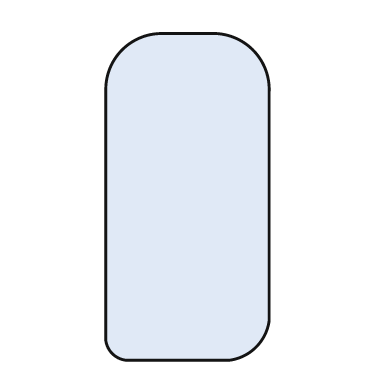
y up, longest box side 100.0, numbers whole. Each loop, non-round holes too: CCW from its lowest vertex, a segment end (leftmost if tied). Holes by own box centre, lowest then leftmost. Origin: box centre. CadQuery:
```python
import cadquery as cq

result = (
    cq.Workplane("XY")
    .moveTo(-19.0, -50.0)
    .lineTo(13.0, -50.0)
    .threePointArc((21.0, -46.0), (25.0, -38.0))
    .lineTo(25.0, 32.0)
    .threePointArc((20.0, 45.0), (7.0, 50.0))
    .lineTo(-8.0, 50.0)
    .threePointArc((-20.0, 45.0), (-25.0, 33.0))
    .lineTo(-25.0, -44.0)
    .threePointArc((-23.0, -48.0), (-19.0, -50.0))
    .close()
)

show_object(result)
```